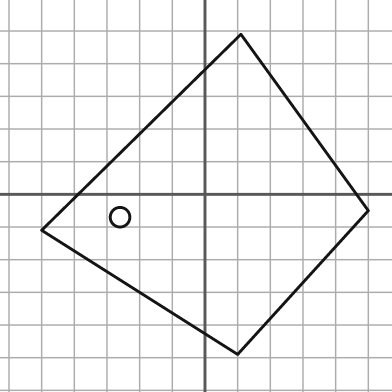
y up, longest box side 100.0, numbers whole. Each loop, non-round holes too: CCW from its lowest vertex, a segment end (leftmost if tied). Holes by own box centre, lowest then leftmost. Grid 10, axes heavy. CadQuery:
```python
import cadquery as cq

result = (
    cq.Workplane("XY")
    .moveTo(10.0, -49.0)
    .lineTo(50.0, -5.0)
    .lineTo(11.0, 49.0)
    .lineTo(-50.0, -11.0)
    .close()
    .moveTo(-26.0, -7.0)
    .circle(3.0)
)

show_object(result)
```